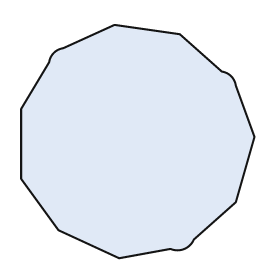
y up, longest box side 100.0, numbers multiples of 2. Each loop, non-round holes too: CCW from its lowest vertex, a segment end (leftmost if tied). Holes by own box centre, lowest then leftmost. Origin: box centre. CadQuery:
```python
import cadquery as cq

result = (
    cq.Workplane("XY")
    .moveTo(-8.0, -50.0)
    .lineTo(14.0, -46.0)
    .threePointArc((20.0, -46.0), (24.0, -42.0))
    .lineTo(42.0, -26.0)
    .lineTo(50.0, 2.0)
    .lineTo(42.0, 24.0)
    .threePointArc((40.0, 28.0), (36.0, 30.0))
    .lineTo(18.0, 46.0)
    .lineTo(-10.0, 50.0)
    .lineTo(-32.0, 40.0)
    .threePointArc((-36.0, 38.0), (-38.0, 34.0))
    .lineTo(-50.0, 14.0)
    .lineTo(-50.0, -16.0)
    .lineTo(-34.0, -38.0)
    .close()
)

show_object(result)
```